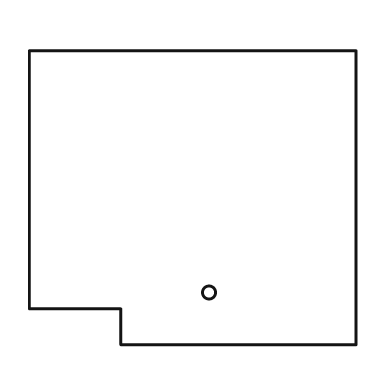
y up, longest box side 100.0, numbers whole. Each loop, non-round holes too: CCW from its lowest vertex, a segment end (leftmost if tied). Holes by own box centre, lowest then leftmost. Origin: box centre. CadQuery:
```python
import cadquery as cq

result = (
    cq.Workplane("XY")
    .moveTo(-22.0, -45.0)
    .lineTo(50.0, -45.0)
    .lineTo(50.0, 45.0)
    .lineTo(-50.0, 45.0)
    .lineTo(-50.0, -34.0)
    .lineTo(-22.0, -34.0)
    .close()
    .moveTo(5.0, -29.0)
    .circle(2.0)
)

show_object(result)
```